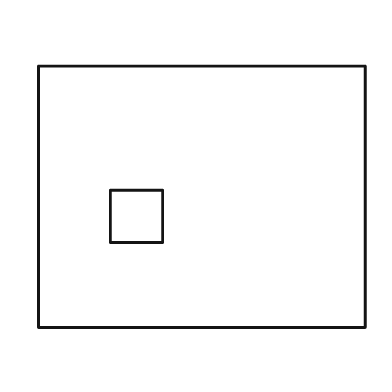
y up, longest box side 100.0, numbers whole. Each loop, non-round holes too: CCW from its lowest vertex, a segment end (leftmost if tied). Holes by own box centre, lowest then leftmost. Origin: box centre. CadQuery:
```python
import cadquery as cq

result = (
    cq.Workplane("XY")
    .moveTo(-50.0, -40.0)
    .lineTo(50.0, -40.0)
    .lineTo(50.0, 40.0)
    .lineTo(-50.0, 40.0)
    .close()
    .moveTo(-28.0, -14.0)
    .lineTo(-12.0, -14.0)
    .lineTo(-12.0, 2.0)
    .lineTo(-28.0, 2.0)
    .close()
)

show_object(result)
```